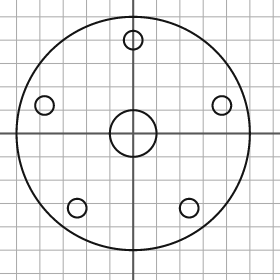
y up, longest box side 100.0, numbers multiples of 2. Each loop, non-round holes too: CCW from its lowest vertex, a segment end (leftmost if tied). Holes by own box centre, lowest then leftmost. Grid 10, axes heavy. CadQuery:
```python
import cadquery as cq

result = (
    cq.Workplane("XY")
    .moveTo(0.0, 0.0)
    .circle(50.0)
    .moveTo(-24.0, -32.0)
    .circle(4.0)
    .moveTo(24.0, -32.0)
    .circle(4.0)
    .moveTo(0.0, 0.0)
    .circle(10.0)
    .moveTo(-38.0, 12.0)
    .circle(4.0)
    .moveTo(38.0, 12.0)
    .circle(4.0)
    .moveTo(0.0, 40.0)
    .circle(4.0)
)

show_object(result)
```